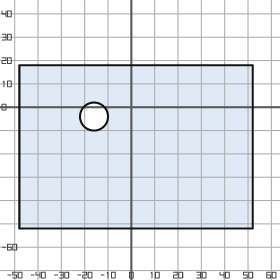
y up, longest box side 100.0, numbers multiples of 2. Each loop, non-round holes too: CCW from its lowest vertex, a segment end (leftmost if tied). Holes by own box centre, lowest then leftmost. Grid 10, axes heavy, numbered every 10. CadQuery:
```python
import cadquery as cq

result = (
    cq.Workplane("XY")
    .moveTo(-48.0, -52.0)
    .lineTo(52.0, -52.0)
    .lineTo(52.0, 18.0)
    .lineTo(-48.0, 18.0)
    .close()
    .moveTo(-16.0, -4.0)
    .circle(6.0)
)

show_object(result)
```